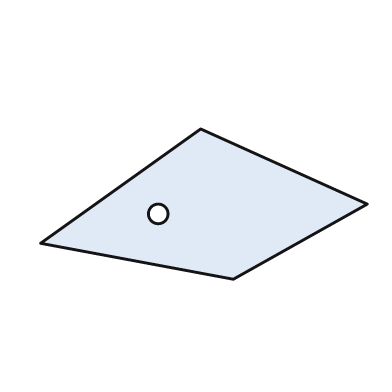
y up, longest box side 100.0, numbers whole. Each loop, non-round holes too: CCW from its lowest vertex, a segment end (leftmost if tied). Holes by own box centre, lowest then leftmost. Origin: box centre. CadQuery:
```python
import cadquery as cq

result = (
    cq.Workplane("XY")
    .moveTo(9.0, -23.0)
    .lineTo(50.0, 0.0)
    .lineTo(-1.0, 23.0)
    .lineTo(-50.0, -12.0)
    .close()
    .moveTo(-14.0, -3.0)
    .circle(3.0)
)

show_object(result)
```